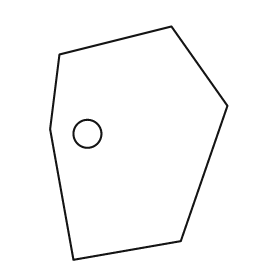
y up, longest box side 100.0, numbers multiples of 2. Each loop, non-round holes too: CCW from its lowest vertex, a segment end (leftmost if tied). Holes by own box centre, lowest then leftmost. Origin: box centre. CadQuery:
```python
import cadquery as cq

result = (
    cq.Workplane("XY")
    .moveTo(-28.0, -50.0)
    .lineTo(18.0, -42.0)
    .lineTo(38.0, 16.0)
    .lineTo(14.0, 50.0)
    .lineTo(-34.0, 38.0)
    .lineTo(-38.0, 6.0)
    .close()
    .moveTo(-22.0, 4.0)
    .circle(6.0)
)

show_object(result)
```